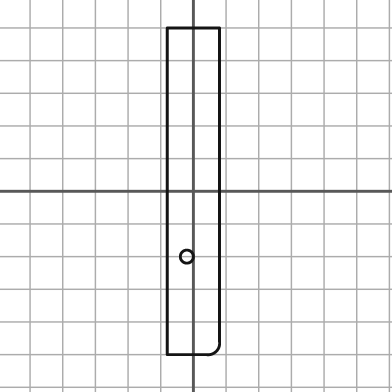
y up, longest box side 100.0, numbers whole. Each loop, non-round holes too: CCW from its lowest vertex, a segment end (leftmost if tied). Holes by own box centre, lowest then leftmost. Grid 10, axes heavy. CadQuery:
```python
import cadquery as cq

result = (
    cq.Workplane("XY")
    .moveTo(-8.0, -50.0)
    .lineTo(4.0, -50.0)
    .threePointArc((7.0, -49.0), (8.0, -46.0))
    .lineTo(8.0, 50.0)
    .lineTo(-8.0, 50.0)
    .close()
    .moveTo(-2.0, -20.0)
    .circle(2.0)
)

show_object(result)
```